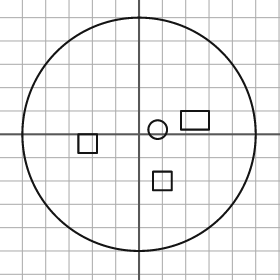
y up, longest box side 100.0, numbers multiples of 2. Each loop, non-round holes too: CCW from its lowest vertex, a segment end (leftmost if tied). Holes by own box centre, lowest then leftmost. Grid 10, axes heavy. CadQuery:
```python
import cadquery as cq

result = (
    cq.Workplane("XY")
    .moveTo(0.0, 0.0)
    .circle(50.0)
    .moveTo(6.0, -24.0)
    .lineTo(14.0, -24.0)
    .lineTo(14.0, -16.0)
    .lineTo(6.0, -16.0)
    .close()
    .moveTo(-26.0, -8.0)
    .lineTo(-18.0, -8.0)
    .lineTo(-18.0, 0.0)
    .lineTo(-26.0, 0.0)
    .close()
    .moveTo(8.0, 2.0)
    .circle(4.0)
    .moveTo(18.0, 2.0)
    .lineTo(30.0, 2.0)
    .lineTo(30.0, 10.0)
    .lineTo(18.0, 10.0)
    .close()
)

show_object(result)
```